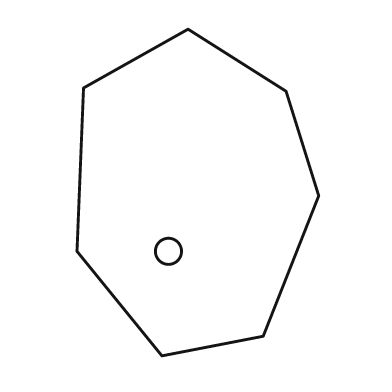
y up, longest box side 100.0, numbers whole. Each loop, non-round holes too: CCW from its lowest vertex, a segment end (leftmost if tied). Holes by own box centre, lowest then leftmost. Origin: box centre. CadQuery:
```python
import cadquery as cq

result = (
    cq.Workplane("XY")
    .moveTo(-11.0, -50.0)
    .lineTo(20.0, -44.0)
    .lineTo(37.0, -1.0)
    .lineTo(27.0, 31.0)
    .lineTo(-3.0, 50.0)
    .lineTo(-35.0, 32.0)
    .lineTo(-37.0, -18.0)
    .close()
    .moveTo(-9.0, -18.0)
    .circle(4.0)
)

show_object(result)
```